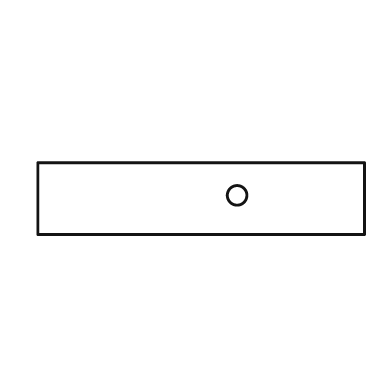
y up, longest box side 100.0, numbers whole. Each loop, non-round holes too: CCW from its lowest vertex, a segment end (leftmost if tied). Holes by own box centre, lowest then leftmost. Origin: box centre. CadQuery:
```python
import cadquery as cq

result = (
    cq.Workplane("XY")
    .moveTo(-50.0, -11.0)
    .lineTo(50.0, -11.0)
    .lineTo(50.0, 11.0)
    .lineTo(-50.0, 11.0)
    .close()
    .moveTo(11.0, 1.0)
    .circle(3.0)
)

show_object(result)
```